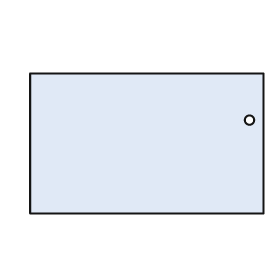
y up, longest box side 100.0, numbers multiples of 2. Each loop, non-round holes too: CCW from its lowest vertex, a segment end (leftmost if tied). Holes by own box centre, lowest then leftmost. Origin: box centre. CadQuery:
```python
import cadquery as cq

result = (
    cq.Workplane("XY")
    .moveTo(-50.0, -30.0)
    .lineTo(50.0, -30.0)
    .lineTo(50.0, 30.0)
    .lineTo(-50.0, 30.0)
    .close()
    .moveTo(44.0, 10.0)
    .circle(2.0)
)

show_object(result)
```